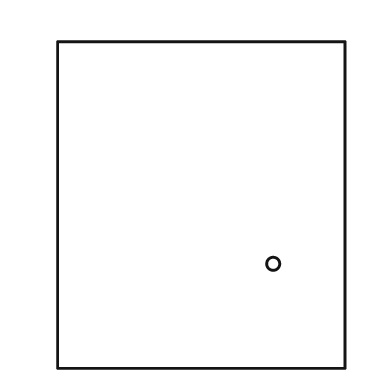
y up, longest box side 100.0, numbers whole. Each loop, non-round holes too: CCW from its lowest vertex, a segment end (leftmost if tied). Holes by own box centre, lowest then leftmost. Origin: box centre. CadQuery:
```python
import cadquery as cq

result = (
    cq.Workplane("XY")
    .moveTo(-44.0, -50.0)
    .lineTo(44.0, -50.0)
    .lineTo(44.0, 50.0)
    .lineTo(-44.0, 50.0)
    .close()
    .moveTo(22.0, -18.0)
    .circle(2.0)
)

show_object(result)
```